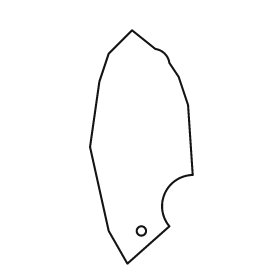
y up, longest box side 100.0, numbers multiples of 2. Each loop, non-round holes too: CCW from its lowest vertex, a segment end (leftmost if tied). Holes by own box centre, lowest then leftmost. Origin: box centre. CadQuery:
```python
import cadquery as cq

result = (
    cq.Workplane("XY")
    .moveTo(-6.0, -50.0)
    .lineTo(12.0, -34.0)
    .threePointArc((10.0, -20.0), (22.0, -12.0))
    .lineTo(20.0, 18.0)
    .lineTo(16.0, 30.0)
    .lineTo(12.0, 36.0)
    .threePointArc((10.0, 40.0), (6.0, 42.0))
    .lineTo(-4.0, 50.0)
    .lineTo(-14.0, 40.0)
    .lineTo(-18.0, 28.0)
    .lineTo(-22.0, 0.0)
    .lineTo(-14.0, -36.0)
    .close()
    .moveTo(0.0, -36.0)
    .circle(2.0)
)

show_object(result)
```